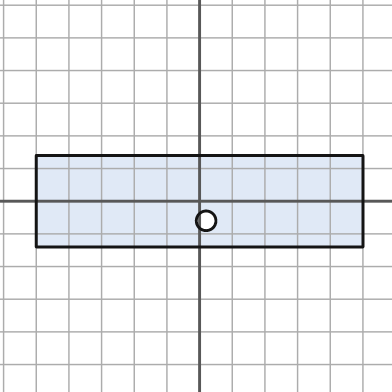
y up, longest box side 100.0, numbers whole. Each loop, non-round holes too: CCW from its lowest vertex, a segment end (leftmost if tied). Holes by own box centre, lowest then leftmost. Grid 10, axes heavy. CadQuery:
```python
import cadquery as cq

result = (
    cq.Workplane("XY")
    .moveTo(-50.0, -14.0)
    .lineTo(50.0, -14.0)
    .lineTo(50.0, 14.0)
    .lineTo(-50.0, 14.0)
    .close()
    .moveTo(2.0, -6.0)
    .circle(3.0)
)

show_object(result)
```